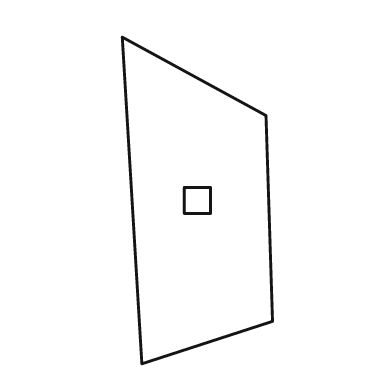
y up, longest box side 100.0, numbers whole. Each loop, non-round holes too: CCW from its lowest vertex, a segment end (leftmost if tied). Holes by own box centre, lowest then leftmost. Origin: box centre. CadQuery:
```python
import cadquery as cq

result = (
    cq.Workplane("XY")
    .moveTo(-17.0, -50.0)
    .lineTo(23.0, -37.0)
    .lineTo(21.0, 26.0)
    .lineTo(-23.0, 50.0)
    .close()
    .moveTo(-4.0, -4.0)
    .lineTo(4.0, -4.0)
    .lineTo(4.0, 4.0)
    .lineTo(-4.0, 4.0)
    .close()
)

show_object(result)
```